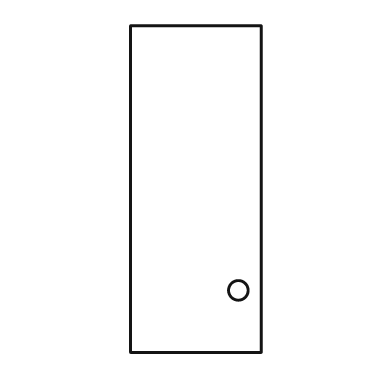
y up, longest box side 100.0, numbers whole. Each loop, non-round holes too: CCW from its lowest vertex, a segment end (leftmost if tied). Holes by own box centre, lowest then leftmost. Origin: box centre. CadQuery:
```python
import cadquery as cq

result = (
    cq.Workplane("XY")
    .moveTo(-20.0, -50.0)
    .lineTo(20.0, -50.0)
    .lineTo(20.0, 50.0)
    .lineTo(-20.0, 50.0)
    .close()
    .moveTo(13.0, -31.0)
    .circle(3.0)
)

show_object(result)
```